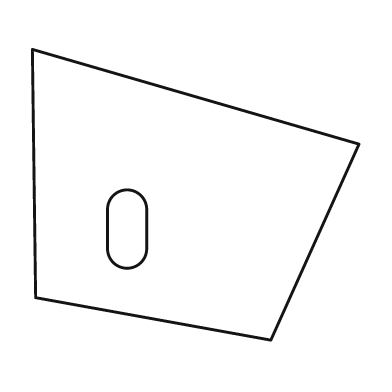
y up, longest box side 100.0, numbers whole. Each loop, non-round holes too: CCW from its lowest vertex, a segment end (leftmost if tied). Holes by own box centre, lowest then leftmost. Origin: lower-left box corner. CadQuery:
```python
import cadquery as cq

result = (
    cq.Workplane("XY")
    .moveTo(73.0, 0.0)
    .lineTo(100.0, 60.0)
    .lineTo(0.0, 89.0)
    .lineTo(1.0, 13.0)
    .close()
    .moveTo(23.0, 28.0)
    .threePointArc((29.0, 22.0), (35.0, 28.0))
    .lineTo(35.0, 40.0)
    .threePointArc((29.0, 46.0), (23.0, 40.0))
    .close()
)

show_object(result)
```